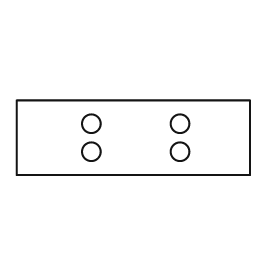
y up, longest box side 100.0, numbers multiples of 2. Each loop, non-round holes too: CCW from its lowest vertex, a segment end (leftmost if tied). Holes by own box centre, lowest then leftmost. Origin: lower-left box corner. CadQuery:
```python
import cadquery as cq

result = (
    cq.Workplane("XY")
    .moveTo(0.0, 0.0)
    .lineTo(100.0, 0.0)
    .lineTo(100.0, 32.0)
    .lineTo(0.0, 32.0)
    .close()
    .moveTo(32.0, 10.0)
    .circle(4.0)
    .moveTo(70.0, 10.0)
    .circle(4.0)
    .moveTo(32.0, 22.0)
    .circle(4.0)
    .moveTo(70.0, 22.0)
    .circle(4.0)
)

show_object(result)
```